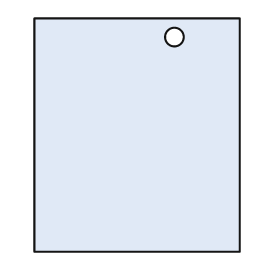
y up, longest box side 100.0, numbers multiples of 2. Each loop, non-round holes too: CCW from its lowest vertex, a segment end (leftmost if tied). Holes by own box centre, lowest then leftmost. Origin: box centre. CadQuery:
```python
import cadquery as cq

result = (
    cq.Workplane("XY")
    .moveTo(-44.0, -50.0)
    .lineTo(44.0, -50.0)
    .lineTo(44.0, 50.0)
    .lineTo(-44.0, 50.0)
    .close()
    .moveTo(16.0, 42.0)
    .circle(4.0)
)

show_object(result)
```